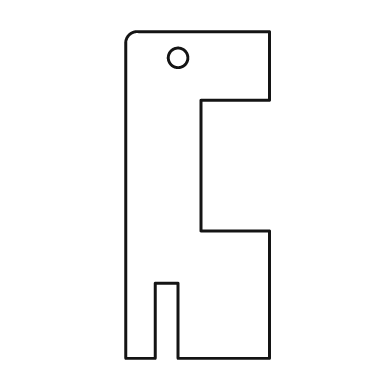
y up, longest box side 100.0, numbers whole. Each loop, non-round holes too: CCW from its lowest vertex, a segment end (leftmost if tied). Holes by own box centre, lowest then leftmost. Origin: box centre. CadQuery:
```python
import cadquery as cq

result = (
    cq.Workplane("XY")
    .moveTo(-22.0, -50.0)
    .lineTo(-13.0, -50.0)
    .lineTo(-13.0, -27.0)
    .lineTo(-6.0, -27.0)
    .lineTo(-6.0, -50.0)
    .lineTo(22.0, -50.0)
    .lineTo(22.0, -11.0)
    .lineTo(1.0, -11.0)
    .lineTo(1.0, 29.0)
    .lineTo(22.0, 29.0)
    .lineTo(22.0, 50.0)
    .lineTo(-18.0, 50.0)
    .threePointArc((-21.0, 49.0), (-22.0, 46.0))
    .close()
    .moveTo(-6.0, 42.0)
    .circle(3.0)
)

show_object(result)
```